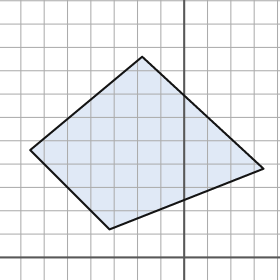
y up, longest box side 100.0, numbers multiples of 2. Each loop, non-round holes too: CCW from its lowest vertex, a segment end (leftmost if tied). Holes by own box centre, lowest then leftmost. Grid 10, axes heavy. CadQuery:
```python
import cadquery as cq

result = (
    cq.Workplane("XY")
    .moveTo(-32.0, 12.0)
    .lineTo(34.0, 38.0)
    .lineTo(-18.0, 86.0)
    .lineTo(-66.0, 46.0)
    .close()
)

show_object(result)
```